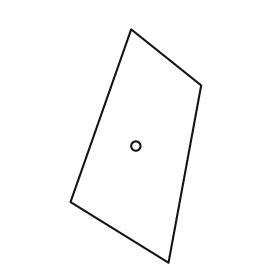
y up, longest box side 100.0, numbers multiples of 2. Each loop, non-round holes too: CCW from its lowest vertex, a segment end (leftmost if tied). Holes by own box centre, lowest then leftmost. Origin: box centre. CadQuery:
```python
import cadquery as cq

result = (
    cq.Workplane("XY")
    .moveTo(14.0, -50.0)
    .lineTo(28.0, 26.0)
    .lineTo(-2.0, 50.0)
    .lineTo(-28.0, -24.0)
    .close()
    .moveTo(0.0, 0.0)
    .circle(2.0)
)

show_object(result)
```